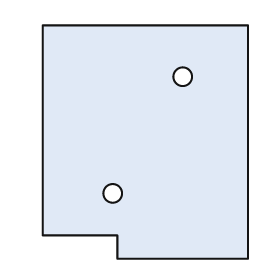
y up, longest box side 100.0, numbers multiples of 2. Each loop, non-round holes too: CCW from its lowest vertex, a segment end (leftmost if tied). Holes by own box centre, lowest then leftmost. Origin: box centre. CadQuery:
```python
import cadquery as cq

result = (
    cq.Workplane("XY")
    .moveTo(-12.0, -50.0)
    .lineTo(44.0, -50.0)
    .lineTo(44.0, 50.0)
    .lineTo(-44.0, 50.0)
    .lineTo(-44.0, -40.0)
    .lineTo(-12.0, -40.0)
    .close()
    .moveTo(-14.0, -22.0)
    .circle(4.0)
    .moveTo(16.0, 28.0)
    .circle(4.0)
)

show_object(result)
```